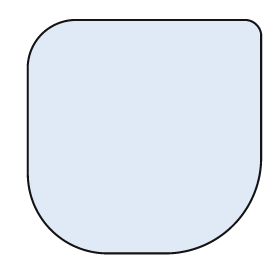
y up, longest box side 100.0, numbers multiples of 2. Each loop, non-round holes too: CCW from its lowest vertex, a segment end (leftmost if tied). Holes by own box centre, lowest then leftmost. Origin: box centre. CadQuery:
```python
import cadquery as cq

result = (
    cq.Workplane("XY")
    .moveTo(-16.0, -50.0)
    .lineTo(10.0, -50.0)
    .threePointArc((38.0, -38.0), (50.0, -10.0))
    .lineTo(50.0, 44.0)
    .threePointArc((48.0, 48.0), (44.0, 50.0))
    .lineTo(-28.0, 50.0)
    .threePointArc((-44.0, 44.0), (-50.0, 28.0))
    .lineTo(-50.0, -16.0)
    .threePointArc((-40.0, -40.0), (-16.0, -50.0))
    .close()
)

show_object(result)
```